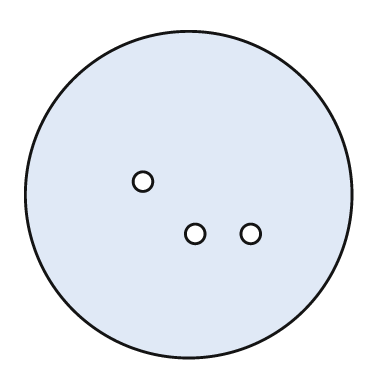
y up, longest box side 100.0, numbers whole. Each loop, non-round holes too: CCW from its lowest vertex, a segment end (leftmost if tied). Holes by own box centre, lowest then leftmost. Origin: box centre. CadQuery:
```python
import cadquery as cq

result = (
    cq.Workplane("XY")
    .moveTo(0.0, 0.0)
    .circle(50.0)
    .moveTo(2.0, -12.0)
    .circle(3.0)
    .moveTo(19.0, -12.0)
    .circle(3.0)
    .moveTo(-14.0, 4.0)
    .circle(3.0)
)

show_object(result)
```